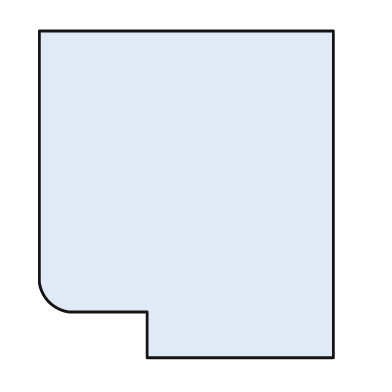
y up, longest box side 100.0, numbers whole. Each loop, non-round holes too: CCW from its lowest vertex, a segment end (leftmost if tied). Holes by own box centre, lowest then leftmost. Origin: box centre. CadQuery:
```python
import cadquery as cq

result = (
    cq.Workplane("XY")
    .moveTo(-12.0, -50.0)
    .lineTo(45.0, -50.0)
    .lineTo(45.0, 50.0)
    .lineTo(-45.0, 50.0)
    .lineTo(-45.0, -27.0)
    .threePointArc((-42.0, -33.0), (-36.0, -36.0))
    .lineTo(-12.0, -36.0)
    .close()
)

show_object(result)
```